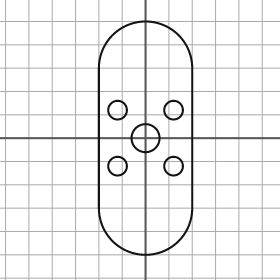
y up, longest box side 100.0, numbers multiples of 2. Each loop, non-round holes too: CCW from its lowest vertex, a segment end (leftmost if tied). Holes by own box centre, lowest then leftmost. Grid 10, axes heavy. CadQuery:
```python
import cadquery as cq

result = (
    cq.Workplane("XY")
    .moveTo(-20.0, -30.0)
    .threePointArc((0.0, -50.0), (20.0, -30.0))
    .lineTo(20.0, 30.0)
    .threePointArc((0.0, 50.0), (-20.0, 30.0))
    .close()
    .moveTo(-12.0, -12.0)
    .circle(4.0)
    .moveTo(12.0, -12.0)
    .circle(4.0)
    .moveTo(0.0, 0.0)
    .circle(6.0)
    .moveTo(-12.0, 12.0)
    .circle(4.0)
    .moveTo(12.0, 12.0)
    .circle(4.0)
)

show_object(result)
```